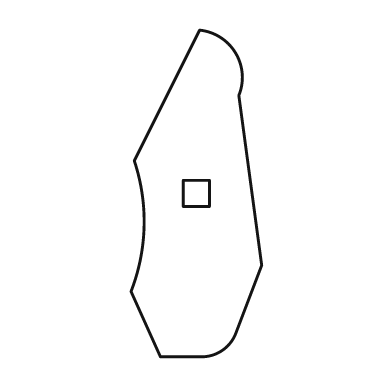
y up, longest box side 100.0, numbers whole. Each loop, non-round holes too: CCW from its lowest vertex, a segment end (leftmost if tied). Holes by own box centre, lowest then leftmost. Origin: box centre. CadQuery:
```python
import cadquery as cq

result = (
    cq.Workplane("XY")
    .moveTo(-11.0, -50.0)
    .lineTo(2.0, -50.0)
    .threePointArc((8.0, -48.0), (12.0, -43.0))
    .lineTo(20.0, -22.0)
    .lineTo(13.0, 30.0)
    .threePointArc((12.0, 43.0), (1.0, 50.0))
    .lineTo(-19.0, 10.0)
    .threePointArc((-16.0, -10.0), (-20.0, -30.0))
    .close()
    .moveTo(-4.0, -4.0)
    .lineTo(4.0, -4.0)
    .lineTo(4.0, 4.0)
    .lineTo(-4.0, 4.0)
    .close()
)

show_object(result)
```